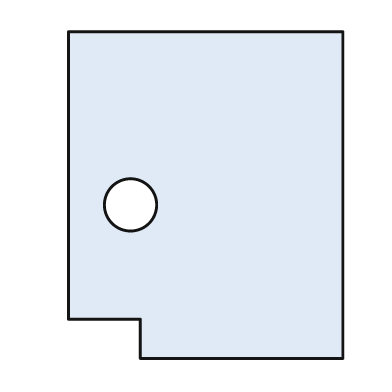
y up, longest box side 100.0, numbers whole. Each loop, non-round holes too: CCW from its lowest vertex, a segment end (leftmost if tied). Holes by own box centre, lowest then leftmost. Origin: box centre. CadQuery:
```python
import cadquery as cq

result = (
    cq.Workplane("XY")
    .moveTo(-20.0, -50.0)
    .lineTo(42.0, -50.0)
    .lineTo(42.0, 50.0)
    .lineTo(-42.0, 50.0)
    .lineTo(-42.0, -38.0)
    .lineTo(-20.0, -38.0)
    .close()
    .moveTo(-23.0, -3.0)
    .circle(8.0)
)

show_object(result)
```